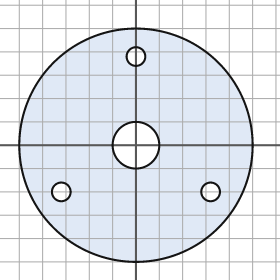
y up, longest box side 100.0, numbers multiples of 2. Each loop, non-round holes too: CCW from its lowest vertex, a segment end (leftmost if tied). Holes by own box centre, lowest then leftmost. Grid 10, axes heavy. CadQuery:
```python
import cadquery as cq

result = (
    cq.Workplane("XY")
    .moveTo(0.0, 0.0)
    .circle(50.0)
    .moveTo(-32.0, -20.0)
    .circle(4.0)
    .moveTo(32.0, -20.0)
    .circle(4.0)
    .moveTo(0.0, 0.0)
    .circle(10.0)
    .moveTo(0.0, 38.0)
    .circle(4.0)
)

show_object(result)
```